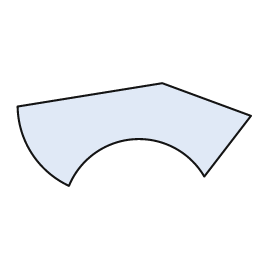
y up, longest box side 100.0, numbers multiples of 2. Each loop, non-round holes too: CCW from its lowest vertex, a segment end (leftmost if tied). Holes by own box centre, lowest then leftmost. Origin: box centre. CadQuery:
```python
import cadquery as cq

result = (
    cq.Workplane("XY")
    .moveTo(-28.0, -22.0)
    .threePointArc((0.0, -2.0), (30.0, -18.0))
    .lineTo(50.0, 8.0)
    .lineTo(12.0, 22.0)
    .lineTo(-50.0, 12.0)
    .threePointArc((-44.0, -8.0), (-28.0, -22.0))
    .close()
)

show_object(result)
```